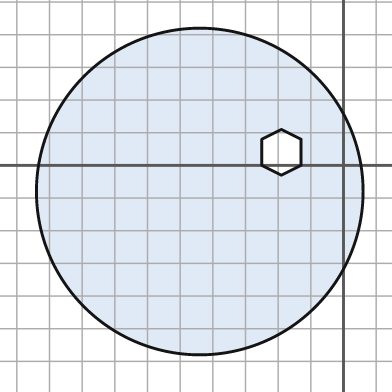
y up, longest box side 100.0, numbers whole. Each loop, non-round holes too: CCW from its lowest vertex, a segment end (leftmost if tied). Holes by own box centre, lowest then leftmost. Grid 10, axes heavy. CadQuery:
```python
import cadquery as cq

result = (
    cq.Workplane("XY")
    .moveTo(-44.0, -8.0)
    .circle(50.0)
    .moveTo(-19.0, -3.0)
    .lineTo(-13.0, 0.0)
    .lineTo(-13.0, 8.0)
    .lineTo(-19.0, 11.0)
    .lineTo(-25.0, 8.0)
    .lineTo(-25.0, 0.0)
    .close()
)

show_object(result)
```